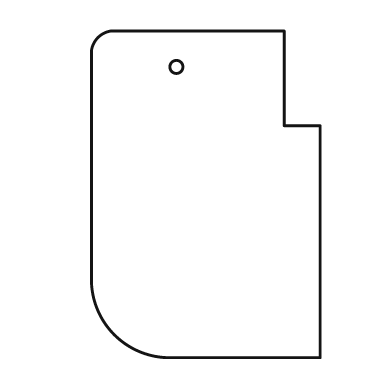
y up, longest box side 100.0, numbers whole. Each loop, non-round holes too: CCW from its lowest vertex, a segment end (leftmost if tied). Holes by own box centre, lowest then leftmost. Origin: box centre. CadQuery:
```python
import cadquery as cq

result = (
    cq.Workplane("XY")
    .moveTo(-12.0, -50.0)
    .lineTo(35.0, -50.0)
    .lineTo(35.0, 21.0)
    .lineTo(24.0, 21.0)
    .lineTo(24.0, 50.0)
    .lineTo(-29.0, 50.0)
    .threePointArc((-33.0, 48.0), (-35.0, 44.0))
    .lineTo(-35.0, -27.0)
    .threePointArc((-28.0, -43.0), (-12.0, -50.0))
    .close()
    .moveTo(-9.0, 39.0)
    .circle(2.0)
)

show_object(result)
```